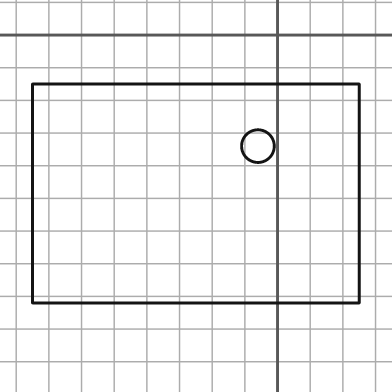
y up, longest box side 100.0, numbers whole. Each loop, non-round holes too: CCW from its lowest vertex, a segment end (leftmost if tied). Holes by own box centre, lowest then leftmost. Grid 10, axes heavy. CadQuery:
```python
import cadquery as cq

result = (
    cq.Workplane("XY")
    .moveTo(-75.0, -82.0)
    .lineTo(25.0, -82.0)
    .lineTo(25.0, -15.0)
    .lineTo(-75.0, -15.0)
    .close()
    .moveTo(-6.0, -34.0)
    .circle(5.0)
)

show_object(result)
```